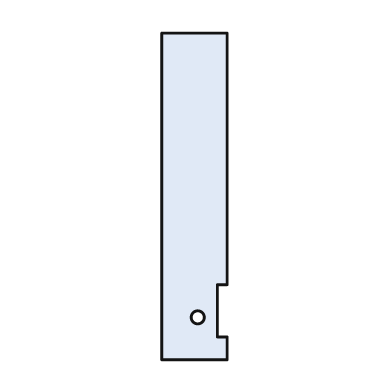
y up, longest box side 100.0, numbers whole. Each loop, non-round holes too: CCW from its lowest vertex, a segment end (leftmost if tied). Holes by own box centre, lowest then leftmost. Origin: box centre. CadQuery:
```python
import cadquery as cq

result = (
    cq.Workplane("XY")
    .moveTo(-10.0, -50.0)
    .lineTo(10.0, -50.0)
    .lineTo(10.0, -43.0)
    .lineTo(7.0, -43.0)
    .lineTo(7.0, -27.0)
    .lineTo(10.0, -27.0)
    .lineTo(10.0, 50.0)
    .lineTo(-10.0, 50.0)
    .close()
    .moveTo(1.0, -37.0)
    .circle(2.0)
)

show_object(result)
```